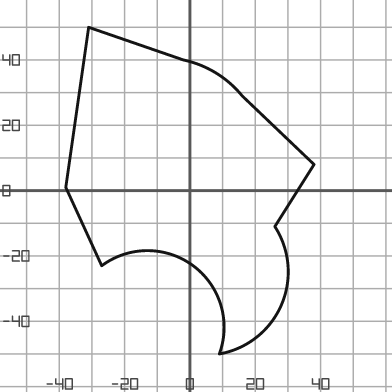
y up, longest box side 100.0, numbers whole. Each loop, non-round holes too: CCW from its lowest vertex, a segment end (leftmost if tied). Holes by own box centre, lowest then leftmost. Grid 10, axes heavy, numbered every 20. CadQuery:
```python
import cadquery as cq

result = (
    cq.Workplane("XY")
    .moveTo(9.0, -50.0)
    .threePointArc((28.0, -35.0), (26.0, -11.0))
    .lineTo(38.0, 8.0)
    .lineTo(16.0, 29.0)
    .threePointArc((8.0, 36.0), (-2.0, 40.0))
    .lineTo(-31.0, 50.0)
    .lineTo(-38.0, 1.0)
    .lineTo(-27.0, -23.0)
    .threePointArc((1.0, -23.0), (9.0, -50.0))
    .close()
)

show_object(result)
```